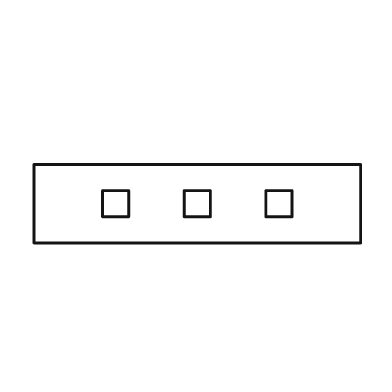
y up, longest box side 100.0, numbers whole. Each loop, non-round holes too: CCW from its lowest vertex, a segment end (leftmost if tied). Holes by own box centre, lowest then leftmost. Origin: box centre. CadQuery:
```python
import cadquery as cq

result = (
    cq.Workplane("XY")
    .moveTo(-50.0, -12.0)
    .lineTo(50.0, -12.0)
    .lineTo(50.0, 12.0)
    .lineTo(-50.0, 12.0)
    .close()
    .moveTo(-29.0, -4.0)
    .lineTo(-21.0, -4.0)
    .lineTo(-21.0, 4.0)
    .lineTo(-29.0, 4.0)
    .close()
    .moveTo(-4.0, -4.0)
    .lineTo(4.0, -4.0)
    .lineTo(4.0, 4.0)
    .lineTo(-4.0, 4.0)
    .close()
    .moveTo(21.0, -4.0)
    .lineTo(29.0, -4.0)
    .lineTo(29.0, 4.0)
    .lineTo(21.0, 4.0)
    .close()
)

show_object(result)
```